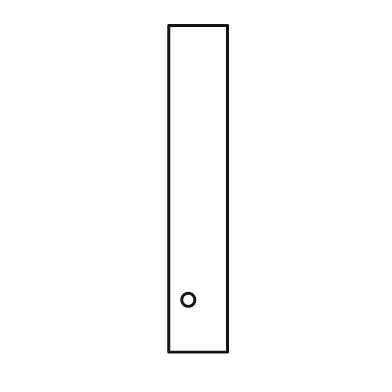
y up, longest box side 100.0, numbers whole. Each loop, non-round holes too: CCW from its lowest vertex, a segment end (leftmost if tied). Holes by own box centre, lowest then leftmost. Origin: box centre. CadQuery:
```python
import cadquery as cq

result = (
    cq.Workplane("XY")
    .moveTo(-9.0, -50.0)
    .lineTo(9.0, -50.0)
    .lineTo(9.0, 50.0)
    .lineTo(-9.0, 50.0)
    .close()
    .moveTo(-3.0, -34.0)
    .circle(2.0)
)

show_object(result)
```